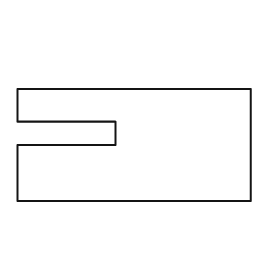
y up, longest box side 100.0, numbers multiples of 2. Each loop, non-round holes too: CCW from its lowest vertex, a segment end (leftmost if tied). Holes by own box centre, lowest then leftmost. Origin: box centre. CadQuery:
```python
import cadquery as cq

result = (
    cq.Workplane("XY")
    .moveTo(-50.0, -24.0)
    .lineTo(50.0, -24.0)
    .lineTo(50.0, 24.0)
    .lineTo(-50.0, 24.0)
    .lineTo(-50.0, 10.0)
    .lineTo(-8.0, 10.0)
    .lineTo(-8.0, 0.0)
    .lineTo(-50.0, 0.0)
    .close()
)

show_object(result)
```